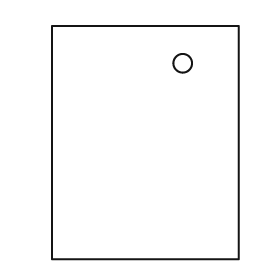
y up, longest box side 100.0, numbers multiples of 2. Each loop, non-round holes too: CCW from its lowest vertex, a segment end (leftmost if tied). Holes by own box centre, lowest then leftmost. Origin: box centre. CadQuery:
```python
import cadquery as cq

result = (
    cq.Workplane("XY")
    .moveTo(-40.0, -50.0)
    .lineTo(40.0, -50.0)
    .lineTo(40.0, 50.0)
    .lineTo(-40.0, 50.0)
    .close()
    .moveTo(16.0, 34.0)
    .circle(4.0)
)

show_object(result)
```